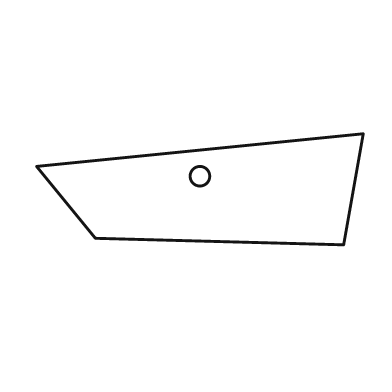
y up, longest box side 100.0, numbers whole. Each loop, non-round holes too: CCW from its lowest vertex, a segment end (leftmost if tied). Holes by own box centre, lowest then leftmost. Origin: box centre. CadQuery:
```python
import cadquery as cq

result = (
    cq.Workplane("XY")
    .moveTo(44.0, -17.0)
    .lineTo(50.0, 17.0)
    .lineTo(-50.0, 7.0)
    .lineTo(-32.0, -15.0)
    .close()
    .moveTo(0.0, 4.0)
    .circle(3.0)
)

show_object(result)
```